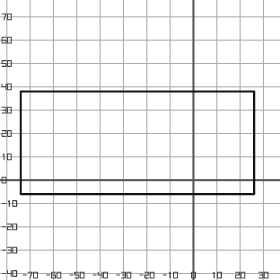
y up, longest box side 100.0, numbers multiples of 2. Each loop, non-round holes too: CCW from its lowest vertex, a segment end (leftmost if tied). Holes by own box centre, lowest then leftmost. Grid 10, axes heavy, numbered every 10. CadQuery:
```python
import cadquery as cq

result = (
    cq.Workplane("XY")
    .moveTo(-74.0, -6.0)
    .lineTo(26.0, -6.0)
    .lineTo(26.0, 38.0)
    .lineTo(-74.0, 38.0)
    .close()
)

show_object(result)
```